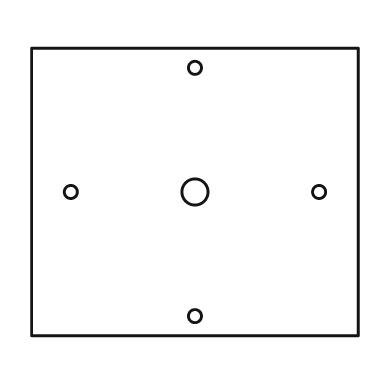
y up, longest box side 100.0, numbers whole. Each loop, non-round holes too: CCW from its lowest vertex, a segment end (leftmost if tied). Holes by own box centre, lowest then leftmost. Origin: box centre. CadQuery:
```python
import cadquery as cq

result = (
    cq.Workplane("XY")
    .moveTo(-50.0, -44.0)
    .lineTo(50.0, -44.0)
    .lineTo(50.0, 44.0)
    .lineTo(-50.0, 44.0)
    .close()
    .moveTo(0.0, -38.0)
    .circle(2.0)
    .moveTo(-38.0, 0.0)
    .circle(2.0)
    .moveTo(0.0, 0.0)
    .circle(4.0)
    .moveTo(38.0, 0.0)
    .circle(2.0)
    .moveTo(0.0, 38.0)
    .circle(2.0)
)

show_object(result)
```